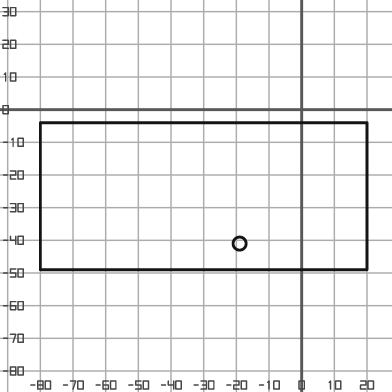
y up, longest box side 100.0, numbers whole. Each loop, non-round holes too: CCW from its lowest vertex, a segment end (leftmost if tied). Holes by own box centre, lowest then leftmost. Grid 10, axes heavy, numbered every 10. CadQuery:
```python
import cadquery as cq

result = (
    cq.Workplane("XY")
    .moveTo(-80.0, -49.0)
    .lineTo(20.0, -49.0)
    .lineTo(20.0, -4.0)
    .lineTo(-80.0, -4.0)
    .close()
    .moveTo(-19.0, -41.0)
    .circle(2.0)
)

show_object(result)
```